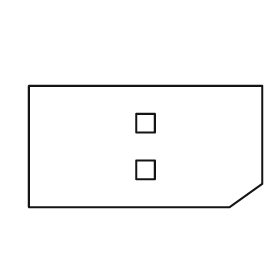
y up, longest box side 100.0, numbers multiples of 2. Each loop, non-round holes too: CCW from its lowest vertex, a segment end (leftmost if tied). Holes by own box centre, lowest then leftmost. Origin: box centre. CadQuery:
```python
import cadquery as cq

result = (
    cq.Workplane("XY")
    .moveTo(-50.0, -26.0)
    .lineTo(36.0, -26.0)
    .lineTo(50.0, -16.0)
    .lineTo(50.0, 26.0)
    .lineTo(-50.0, 26.0)
    .close()
    .moveTo(-4.0, -14.0)
    .lineTo(4.0, -14.0)
    .lineTo(4.0, -6.0)
    .lineTo(-4.0, -6.0)
    .close()
    .moveTo(-4.0, 6.0)
    .lineTo(4.0, 6.0)
    .lineTo(4.0, 14.0)
    .lineTo(-4.0, 14.0)
    .close()
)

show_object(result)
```